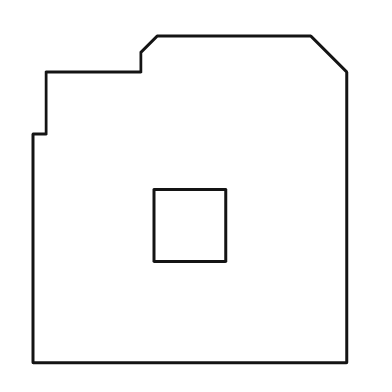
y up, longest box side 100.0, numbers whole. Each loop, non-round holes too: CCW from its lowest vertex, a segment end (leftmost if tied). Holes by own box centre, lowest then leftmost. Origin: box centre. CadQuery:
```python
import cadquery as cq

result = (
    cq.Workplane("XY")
    .moveTo(-48.0, -50.0)
    .lineTo(48.0, -50.0)
    .lineTo(48.0, 39.0)
    .lineTo(37.0, 50.0)
    .lineTo(-10.0, 50.0)
    .lineTo(-15.0, 45.0)
    .lineTo(-15.0, 39.0)
    .lineTo(-44.0, 39.0)
    .lineTo(-44.0, 20.0)
    .lineTo(-48.0, 20.0)
    .close()
    .moveTo(-11.0, -19.0)
    .lineTo(11.0, -19.0)
    .lineTo(11.0, 3.0)
    .lineTo(-11.0, 3.0)
    .close()
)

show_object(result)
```